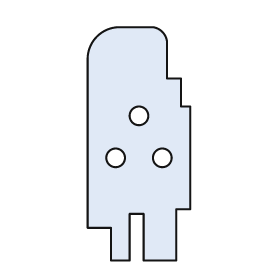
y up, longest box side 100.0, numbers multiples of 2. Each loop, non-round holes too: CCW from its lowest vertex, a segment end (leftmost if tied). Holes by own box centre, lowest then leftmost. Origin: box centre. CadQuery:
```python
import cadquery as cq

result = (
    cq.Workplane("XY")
    .moveTo(-12.0, -50.0)
    .lineTo(-4.0, -50.0)
    .lineTo(-4.0, -30.0)
    .lineTo(2.0, -30.0)
    .lineTo(2.0, -50.0)
    .lineTo(16.0, -50.0)
    .lineTo(16.0, -28.0)
    .lineTo(22.0, -28.0)
    .lineTo(22.0, 16.0)
    .lineTo(18.0, 16.0)
    .lineTo(18.0, 28.0)
    .lineTo(12.0, 28.0)
    .lineTo(12.0, 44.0)
    .threePointArc((10.0, 48.0), (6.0, 50.0))
    .lineTo(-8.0, 50.0)
    .threePointArc((-18.0, 46.0), (-22.0, 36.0))
    .lineTo(-22.0, -36.0)
    .lineTo(-12.0, -36.0)
    .close()
    .moveTo(-10.0, -6.0)
    .circle(4.0)
    .moveTo(10.0, -6.0)
    .circle(4.0)
    .moveTo(0.0, 12.0)
    .circle(4.0)
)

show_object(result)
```